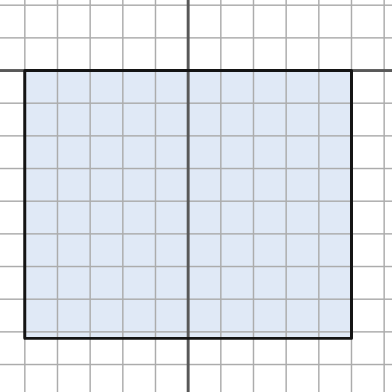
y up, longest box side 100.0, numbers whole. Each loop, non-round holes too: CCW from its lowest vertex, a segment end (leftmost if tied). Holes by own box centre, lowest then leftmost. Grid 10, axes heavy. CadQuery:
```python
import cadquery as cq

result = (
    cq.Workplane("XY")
    .moveTo(-50.0, -82.0)
    .lineTo(50.0, -82.0)
    .lineTo(50.0, 0.0)
    .lineTo(-50.0, 0.0)
    .close()
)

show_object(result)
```